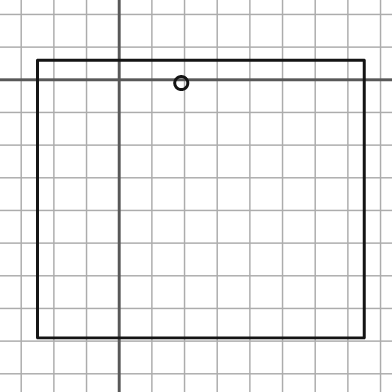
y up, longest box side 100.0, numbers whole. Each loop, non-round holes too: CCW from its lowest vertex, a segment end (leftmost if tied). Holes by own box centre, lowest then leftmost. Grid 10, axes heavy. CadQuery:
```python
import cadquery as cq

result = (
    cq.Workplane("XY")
    .moveTo(-25.0, -79.0)
    .lineTo(75.0, -79.0)
    .lineTo(75.0, 6.0)
    .lineTo(-25.0, 6.0)
    .close()
    .moveTo(19.0, -1.0)
    .circle(2.0)
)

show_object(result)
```